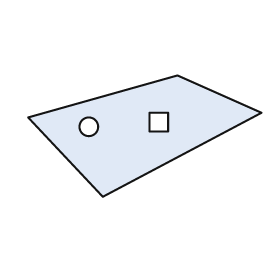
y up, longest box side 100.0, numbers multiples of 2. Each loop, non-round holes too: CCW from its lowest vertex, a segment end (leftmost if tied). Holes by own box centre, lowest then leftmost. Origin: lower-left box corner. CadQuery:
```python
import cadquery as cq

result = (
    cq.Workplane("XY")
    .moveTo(32.0, 0.0)
    .lineTo(100.0, 36.0)
    .lineTo(64.0, 52.0)
    .lineTo(0.0, 34.0)
    .close()
    .moveTo(26.0, 30.0)
    .circle(4.0)
    .moveTo(52.0, 28.0)
    .lineTo(60.0, 28.0)
    .lineTo(60.0, 36.0)
    .lineTo(52.0, 36.0)
    .close()
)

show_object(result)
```